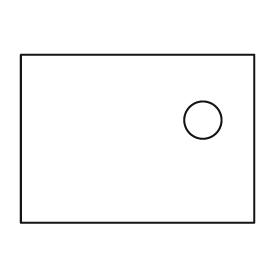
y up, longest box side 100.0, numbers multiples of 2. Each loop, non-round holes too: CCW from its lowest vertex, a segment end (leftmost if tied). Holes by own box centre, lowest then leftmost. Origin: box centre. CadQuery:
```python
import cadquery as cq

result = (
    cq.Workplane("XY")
    .moveTo(-50.0, -36.0)
    .lineTo(50.0, -36.0)
    .lineTo(50.0, 36.0)
    .lineTo(-50.0, 36.0)
    .close()
    .moveTo(28.0, 8.0)
    .circle(8.0)
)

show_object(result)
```